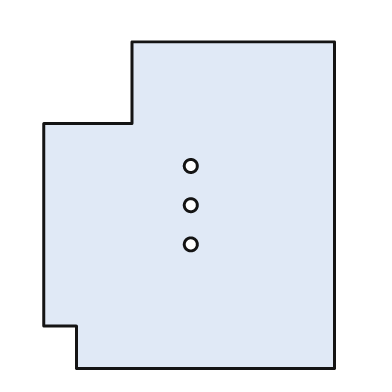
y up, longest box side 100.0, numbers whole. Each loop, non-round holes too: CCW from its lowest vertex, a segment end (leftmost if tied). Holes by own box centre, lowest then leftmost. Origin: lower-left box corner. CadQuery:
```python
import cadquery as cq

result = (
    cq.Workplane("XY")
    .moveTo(10.0, 0.0)
    .lineTo(89.0, 0.0)
    .lineTo(89.0, 100.0)
    .lineTo(27.0, 100.0)
    .lineTo(27.0, 75.0)
    .lineTo(0.0, 75.0)
    .lineTo(0.0, 13.0)
    .lineTo(10.0, 13.0)
    .close()
    .moveTo(45.0, 38.0)
    .circle(2.0)
    .moveTo(45.0, 50.0)
    .circle(2.0)
    .moveTo(45.0, 62.0)
    .circle(2.0)
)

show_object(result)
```